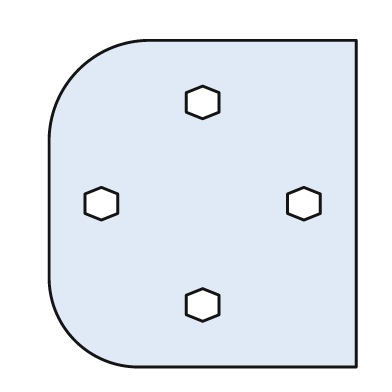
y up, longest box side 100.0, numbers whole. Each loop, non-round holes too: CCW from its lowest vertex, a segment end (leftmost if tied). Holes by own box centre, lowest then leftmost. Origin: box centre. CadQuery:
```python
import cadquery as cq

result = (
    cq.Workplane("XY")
    .moveTo(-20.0, -50.0)
    .lineTo(47.0, -50.0)
    .lineTo(47.0, 50.0)
    .lineTo(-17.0, 50.0)
    .threePointArc((-38.0, 41.0), (-47.0, 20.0))
    .lineTo(-47.0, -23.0)
    .threePointArc((-39.0, -42.0), (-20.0, -50.0))
    .close()
    .moveTo(0.0, -36.0)
    .lineTo(5.0, -34.0)
    .lineTo(5.0, -28.0)
    .lineTo(0.0, -26.0)
    .lineTo(-5.0, -28.0)
    .lineTo(-5.0, -34.0)
    .close()
    .moveTo(-31.0, -5.0)
    .lineTo(-26.0, -3.0)
    .lineTo(-26.0, 3.0)
    .lineTo(-31.0, 5.0)
    .lineTo(-36.0, 3.0)
    .lineTo(-36.0, -3.0)
    .close()
    .moveTo(31.0, -5.0)
    .lineTo(36.0, -3.0)
    .lineTo(36.0, 3.0)
    .lineTo(31.0, 5.0)
    .lineTo(26.0, 3.0)
    .lineTo(26.0, -3.0)
    .close()
    .moveTo(0.0, 26.0)
    .lineTo(5.0, 28.0)
    .lineTo(5.0, 34.0)
    .lineTo(0.0, 36.0)
    .lineTo(-5.0, 34.0)
    .lineTo(-5.0, 28.0)
    .close()
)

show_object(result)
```